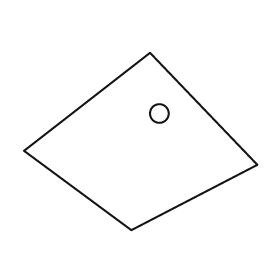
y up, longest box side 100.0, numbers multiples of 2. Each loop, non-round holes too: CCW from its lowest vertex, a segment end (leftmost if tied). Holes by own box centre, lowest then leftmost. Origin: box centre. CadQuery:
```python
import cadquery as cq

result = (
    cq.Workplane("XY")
    .moveTo(-4.0, -38.0)
    .lineTo(50.0, -10.0)
    .lineTo(4.0, 38.0)
    .lineTo(-50.0, -4.0)
    .close()
    .moveTo(8.0, 12.0)
    .circle(4.0)
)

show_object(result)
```